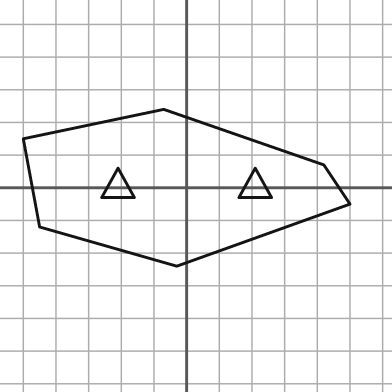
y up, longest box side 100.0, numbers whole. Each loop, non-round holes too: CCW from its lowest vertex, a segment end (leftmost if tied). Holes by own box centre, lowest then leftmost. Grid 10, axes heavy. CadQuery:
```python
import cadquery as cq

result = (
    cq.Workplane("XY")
    .moveTo(-3.0, -24.0)
    .lineTo(50.0, -5.0)
    .lineTo(42.0, 7.0)
    .lineTo(-7.0, 24.0)
    .lineTo(-50.0, 15.0)
    .lineTo(-45.0, -12.0)
    .close()
    .moveTo(-26.0, -3.0)
    .lineTo(-16.0, -3.0)
    .lineTo(-21.0, 6.0)
    .close()
    .moveTo(16.0, -3.0)
    .lineTo(26.0, -3.0)
    .lineTo(21.0, 6.0)
    .close()
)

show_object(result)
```